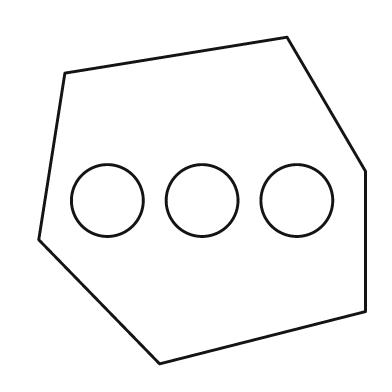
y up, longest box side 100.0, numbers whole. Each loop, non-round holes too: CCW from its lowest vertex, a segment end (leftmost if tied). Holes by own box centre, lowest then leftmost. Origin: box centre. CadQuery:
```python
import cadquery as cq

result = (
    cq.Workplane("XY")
    .moveTo(-13.0, -50.0)
    .lineTo(50.0, -34.0)
    .lineTo(50.0, 9.0)
    .lineTo(26.0, 50.0)
    .lineTo(-42.0, 39.0)
    .lineTo(-50.0, -12.0)
    .close()
    .moveTo(-29.0, 0.0)
    .circle(11.0)
    .moveTo(0.0, 0.0)
    .circle(11.0)
    .moveTo(29.0, 0.0)
    .circle(11.0)
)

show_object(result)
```